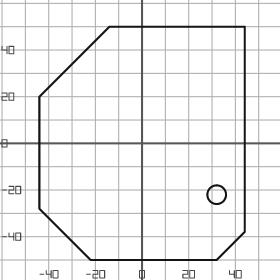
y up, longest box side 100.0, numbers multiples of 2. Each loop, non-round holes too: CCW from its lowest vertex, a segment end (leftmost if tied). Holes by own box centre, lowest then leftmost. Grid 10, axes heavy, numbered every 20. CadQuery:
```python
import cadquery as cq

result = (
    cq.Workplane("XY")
    .moveTo(-22.0, -50.0)
    .lineTo(32.0, -50.0)
    .lineTo(44.0, -38.0)
    .lineTo(44.0, 50.0)
    .lineTo(-14.0, 50.0)
    .lineTo(-44.0, 20.0)
    .lineTo(-44.0, -28.0)
    .close()
    .moveTo(32.0, -22.0)
    .circle(4.0)
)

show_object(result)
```